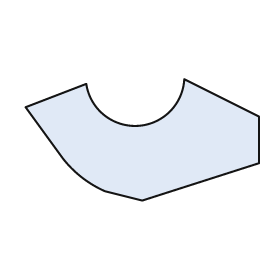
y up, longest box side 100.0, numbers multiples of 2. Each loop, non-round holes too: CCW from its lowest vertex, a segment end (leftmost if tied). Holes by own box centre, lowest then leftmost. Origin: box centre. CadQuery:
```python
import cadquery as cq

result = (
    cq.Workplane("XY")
    .moveTo(0.0, -26.0)
    .lineTo(50.0, -10.0)
    .lineTo(50.0, 10.0)
    .lineTo(18.0, 26.0)
    .threePointArc((-2.0, 6.0), (-24.0, 24.0))
    .lineTo(-50.0, 14.0)
    .lineTo(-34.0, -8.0)
    .threePointArc((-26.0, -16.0), (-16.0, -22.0))
    .close()
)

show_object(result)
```